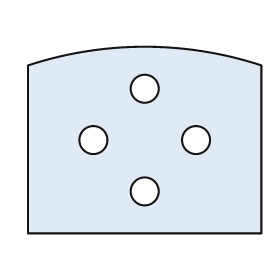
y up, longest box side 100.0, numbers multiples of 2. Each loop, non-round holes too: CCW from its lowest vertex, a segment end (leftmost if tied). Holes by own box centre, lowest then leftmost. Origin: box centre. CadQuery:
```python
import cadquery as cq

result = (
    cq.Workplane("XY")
    .moveTo(-50.0, -40.0)
    .lineTo(50.0, -40.0)
    .lineTo(50.0, 32.0)
    .threePointArc((0.0, 40.0), (-50.0, 32.0))
    .close()
    .moveTo(0.0, -22.0)
    .circle(6.0)
    .moveTo(-22.0, 0.0)
    .circle(6.0)
    .moveTo(22.0, 0.0)
    .circle(6.0)
    .moveTo(0.0, 22.0)
    .circle(6.0)
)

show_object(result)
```